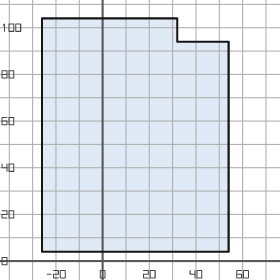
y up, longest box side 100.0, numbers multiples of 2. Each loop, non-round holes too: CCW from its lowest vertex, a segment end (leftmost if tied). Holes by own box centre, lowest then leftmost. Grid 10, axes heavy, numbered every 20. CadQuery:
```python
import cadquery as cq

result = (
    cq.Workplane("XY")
    .moveTo(-26.0, 4.0)
    .lineTo(54.0, 4.0)
    .lineTo(54.0, 94.0)
    .lineTo(32.0, 94.0)
    .lineTo(32.0, 104.0)
    .lineTo(-26.0, 104.0)
    .close()
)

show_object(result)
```